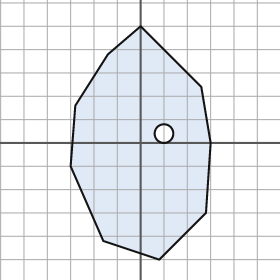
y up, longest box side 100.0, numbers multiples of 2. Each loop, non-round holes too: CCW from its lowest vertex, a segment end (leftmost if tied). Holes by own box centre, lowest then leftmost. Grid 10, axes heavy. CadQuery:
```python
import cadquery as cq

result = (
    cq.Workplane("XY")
    .moveTo(8.0, -50.0)
    .lineTo(28.0, -30.0)
    .lineTo(30.0, 0.0)
    .lineTo(26.0, 24.0)
    .lineTo(0.0, 50.0)
    .lineTo(-14.0, 38.0)
    .lineTo(-28.0, 16.0)
    .lineTo(-30.0, -10.0)
    .lineTo(-16.0, -42.0)
    .close()
    .moveTo(10.0, 4.0)
    .circle(4.0)
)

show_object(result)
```